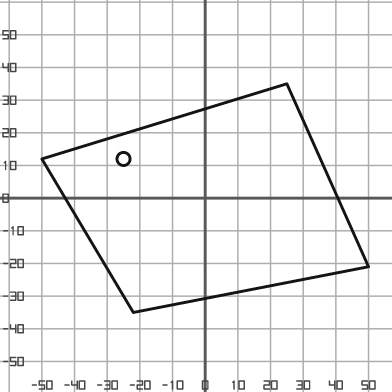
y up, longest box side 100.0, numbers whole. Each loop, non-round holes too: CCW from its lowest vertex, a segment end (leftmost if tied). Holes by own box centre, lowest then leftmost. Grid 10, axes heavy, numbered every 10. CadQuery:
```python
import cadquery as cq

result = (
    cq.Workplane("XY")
    .moveTo(-22.0, -35.0)
    .lineTo(50.0, -21.0)
    .lineTo(25.0, 35.0)
    .lineTo(-50.0, 12.0)
    .close()
    .moveTo(-25.0, 12.0)
    .circle(2.0)
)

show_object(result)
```